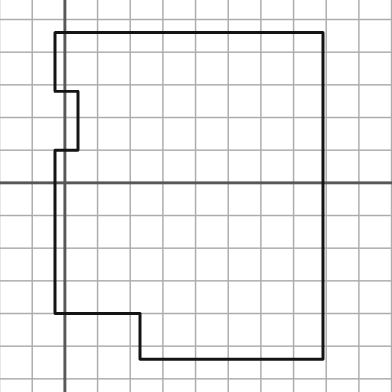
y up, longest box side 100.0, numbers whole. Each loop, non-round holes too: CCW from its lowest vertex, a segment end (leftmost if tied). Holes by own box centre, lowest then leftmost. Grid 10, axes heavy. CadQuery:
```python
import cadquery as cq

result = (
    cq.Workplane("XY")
    .moveTo(23.0, -54.0)
    .lineTo(79.0, -54.0)
    .lineTo(79.0, 46.0)
    .lineTo(-3.0, 46.0)
    .lineTo(-3.0, 28.0)
    .lineTo(4.0, 28.0)
    .lineTo(4.0, 10.0)
    .lineTo(-3.0, 10.0)
    .lineTo(-3.0, -40.0)
    .lineTo(23.0, -40.0)
    .close()
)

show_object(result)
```